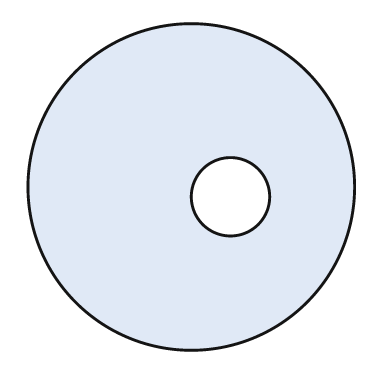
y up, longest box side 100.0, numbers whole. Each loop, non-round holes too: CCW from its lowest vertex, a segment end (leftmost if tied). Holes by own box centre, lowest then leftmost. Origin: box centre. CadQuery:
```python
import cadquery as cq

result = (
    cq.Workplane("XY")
    .moveTo(0.0, 0.0)
    .circle(50.0)
    .moveTo(12.0, -3.0)
    .circle(12.0)
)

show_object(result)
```